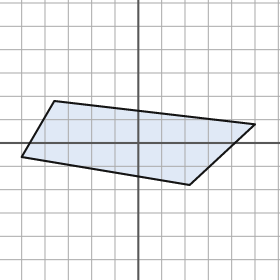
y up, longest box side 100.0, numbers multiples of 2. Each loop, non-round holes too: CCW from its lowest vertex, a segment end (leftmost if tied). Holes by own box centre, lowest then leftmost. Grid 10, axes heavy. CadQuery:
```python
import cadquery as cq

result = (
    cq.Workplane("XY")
    .moveTo(22.0, -18.0)
    .lineTo(50.0, 8.0)
    .lineTo(-36.0, 18.0)
    .lineTo(-50.0, -6.0)
    .close()
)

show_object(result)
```